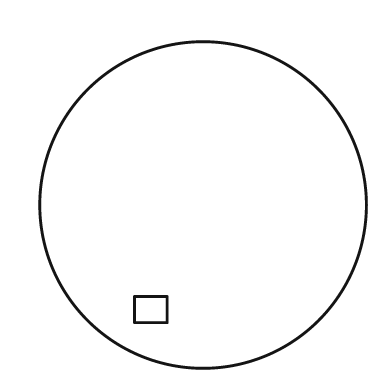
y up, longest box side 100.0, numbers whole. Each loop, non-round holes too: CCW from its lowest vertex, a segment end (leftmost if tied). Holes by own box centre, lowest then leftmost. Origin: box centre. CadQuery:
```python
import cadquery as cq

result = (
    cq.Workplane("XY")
    .moveTo(0.0, 0.0)
    .circle(50.0)
    .moveTo(-21.0, -36.0)
    .lineTo(-11.0, -36.0)
    .lineTo(-11.0, -28.0)
    .lineTo(-21.0, -28.0)
    .close()
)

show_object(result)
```